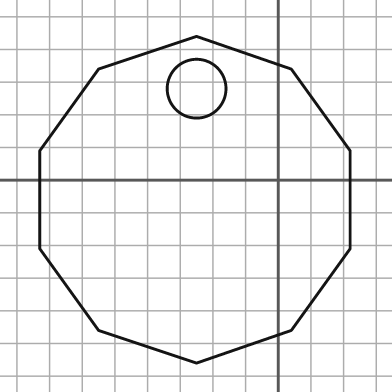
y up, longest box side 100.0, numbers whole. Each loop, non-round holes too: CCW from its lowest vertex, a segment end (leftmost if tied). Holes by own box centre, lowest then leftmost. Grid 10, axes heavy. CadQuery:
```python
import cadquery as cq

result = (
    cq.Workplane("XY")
    .moveTo(-25.0, -56.0)
    .lineTo(4.0, -46.0)
    .lineTo(22.0, -21.0)
    .lineTo(22.0, 9.0)
    .lineTo(4.0, 34.0)
    .lineTo(-25.0, 44.0)
    .lineTo(-55.0, 34.0)
    .lineTo(-73.0, 9.0)
    .lineTo(-73.0, -21.0)
    .lineTo(-55.0, -46.0)
    .close()
    .moveTo(-25.0, 28.0)
    .circle(9.0)
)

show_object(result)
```